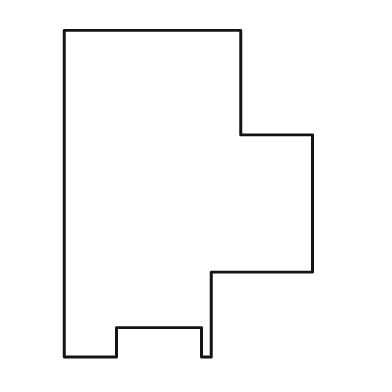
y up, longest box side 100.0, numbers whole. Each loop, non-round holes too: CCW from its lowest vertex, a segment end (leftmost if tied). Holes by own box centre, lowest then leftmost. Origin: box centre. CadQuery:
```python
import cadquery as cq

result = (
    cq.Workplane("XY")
    .moveTo(-38.0, -50.0)
    .lineTo(-22.0, -50.0)
    .lineTo(-22.0, -41.0)
    .lineTo(4.0, -41.0)
    .lineTo(4.0, -50.0)
    .lineTo(7.0, -50.0)
    .lineTo(7.0, -24.0)
    .lineTo(38.0, -24.0)
    .lineTo(38.0, 18.0)
    .lineTo(16.0, 18.0)
    .lineTo(16.0, 50.0)
    .lineTo(-38.0, 50.0)
    .close()
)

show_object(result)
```